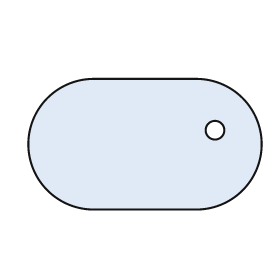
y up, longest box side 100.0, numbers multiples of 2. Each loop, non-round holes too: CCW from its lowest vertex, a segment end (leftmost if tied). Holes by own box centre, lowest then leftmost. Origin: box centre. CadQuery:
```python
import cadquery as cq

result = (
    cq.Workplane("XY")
    .moveTo(-22.0, -28.0)
    .lineTo(22.0, -28.0)
    .threePointArc((50.0, 0.0), (22.0, 28.0))
    .lineTo(-22.0, 28.0)
    .threePointArc((-50.0, 0.0), (-22.0, -28.0))
    .close()
    .moveTo(30.0, 6.0)
    .circle(4.0)
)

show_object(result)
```